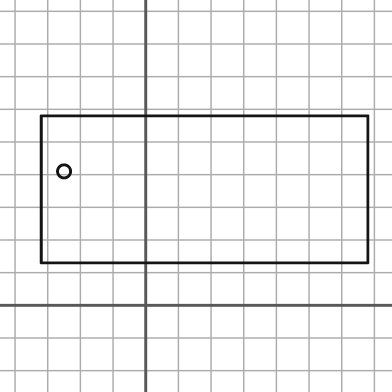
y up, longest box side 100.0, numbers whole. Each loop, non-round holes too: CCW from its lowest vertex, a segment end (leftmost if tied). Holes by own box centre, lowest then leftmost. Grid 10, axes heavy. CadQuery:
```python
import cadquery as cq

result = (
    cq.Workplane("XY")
    .moveTo(-32.0, 13.0)
    .lineTo(68.0, 13.0)
    .lineTo(68.0, 58.0)
    .lineTo(-32.0, 58.0)
    .close()
    .moveTo(-25.0, 41.0)
    .circle(2.0)
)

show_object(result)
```